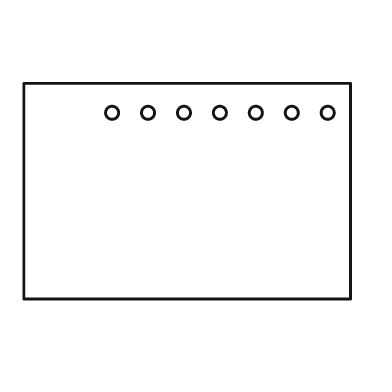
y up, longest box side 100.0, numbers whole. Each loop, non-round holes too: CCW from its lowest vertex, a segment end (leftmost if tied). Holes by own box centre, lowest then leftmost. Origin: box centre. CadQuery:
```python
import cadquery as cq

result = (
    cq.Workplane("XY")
    .moveTo(-50.0, -33.0)
    .lineTo(50.0, -33.0)
    .lineTo(50.0, 33.0)
    .lineTo(-50.0, 33.0)
    .close()
    .moveTo(-23.0, 24.0)
    .circle(2.0)
    .moveTo(-12.0, 24.0)
    .circle(2.0)
    .moveTo(-1.0, 24.0)
    .circle(2.0)
    .moveTo(10.0, 24.0)
    .circle(2.0)
    .moveTo(21.0, 24.0)
    .circle(2.0)
    .moveTo(32.0, 24.0)
    .circle(2.0)
    .moveTo(43.0, 24.0)
    .circle(2.0)
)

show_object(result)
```